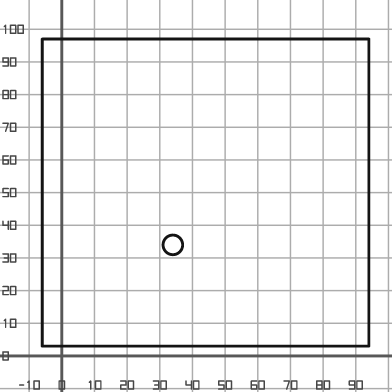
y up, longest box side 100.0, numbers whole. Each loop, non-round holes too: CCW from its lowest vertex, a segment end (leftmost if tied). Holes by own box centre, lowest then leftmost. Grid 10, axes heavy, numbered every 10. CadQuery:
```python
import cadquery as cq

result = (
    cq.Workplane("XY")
    .moveTo(-6.0, 3.0)
    .lineTo(94.0, 3.0)
    .lineTo(94.0, 97.0)
    .lineTo(-6.0, 97.0)
    .close()
    .moveTo(34.0, 34.0)
    .circle(3.0)
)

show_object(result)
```